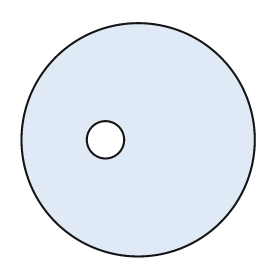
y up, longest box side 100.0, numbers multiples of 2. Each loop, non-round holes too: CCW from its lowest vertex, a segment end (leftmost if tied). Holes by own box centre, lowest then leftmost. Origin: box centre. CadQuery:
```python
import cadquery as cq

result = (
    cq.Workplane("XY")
    .moveTo(0.0, 0.0)
    .circle(50.0)
    .moveTo(-14.0, 0.0)
    .circle(8.0)
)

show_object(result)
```